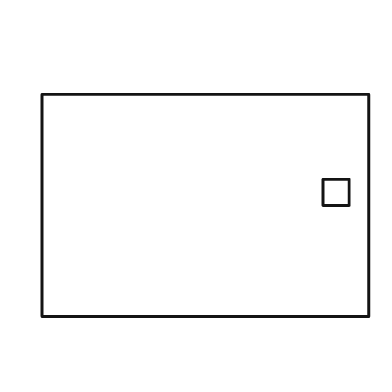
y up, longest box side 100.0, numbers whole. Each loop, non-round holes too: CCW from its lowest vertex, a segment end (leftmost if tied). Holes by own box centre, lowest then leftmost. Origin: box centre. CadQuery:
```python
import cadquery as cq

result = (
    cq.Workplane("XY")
    .moveTo(-50.0, -34.0)
    .lineTo(50.0, -34.0)
    .lineTo(50.0, 34.0)
    .lineTo(-50.0, 34.0)
    .close()
    .moveTo(36.0, 0.0)
    .lineTo(44.0, 0.0)
    .lineTo(44.0, 8.0)
    .lineTo(36.0, 8.0)
    .close()
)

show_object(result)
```